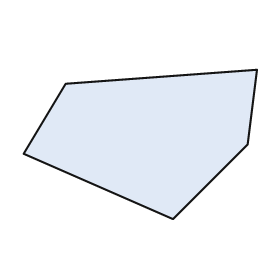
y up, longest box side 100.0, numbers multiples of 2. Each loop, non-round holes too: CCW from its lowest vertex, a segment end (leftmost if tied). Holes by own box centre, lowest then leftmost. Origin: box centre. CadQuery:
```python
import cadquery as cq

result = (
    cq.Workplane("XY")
    .moveTo(14.0, -32.0)
    .lineTo(46.0, 0.0)
    .lineTo(50.0, 32.0)
    .lineTo(-32.0, 26.0)
    .lineTo(-50.0, -4.0)
    .close()
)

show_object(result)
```